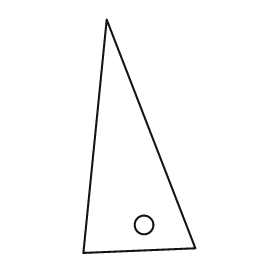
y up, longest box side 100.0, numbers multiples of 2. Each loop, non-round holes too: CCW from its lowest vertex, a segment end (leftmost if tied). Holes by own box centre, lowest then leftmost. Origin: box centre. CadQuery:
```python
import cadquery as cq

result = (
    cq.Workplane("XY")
    .moveTo(-24.0, -50.0)
    .lineTo(24.0, -48.0)
    .lineTo(-14.0, 50.0)
    .close()
    .moveTo(2.0, -38.0)
    .circle(4.0)
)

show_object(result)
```